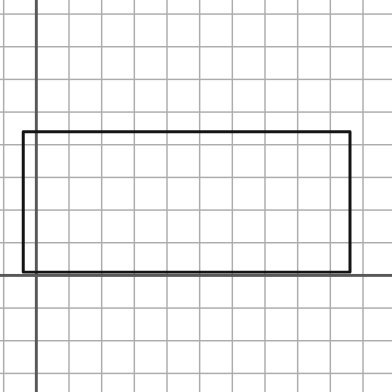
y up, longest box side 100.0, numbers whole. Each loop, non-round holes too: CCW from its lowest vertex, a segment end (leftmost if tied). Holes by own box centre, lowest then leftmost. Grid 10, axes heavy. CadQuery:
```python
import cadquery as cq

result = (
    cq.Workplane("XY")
    .moveTo(-4.0, 1.0)
    .lineTo(96.0, 1.0)
    .lineTo(96.0, 44.0)
    .lineTo(-4.0, 44.0)
    .close()
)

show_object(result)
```